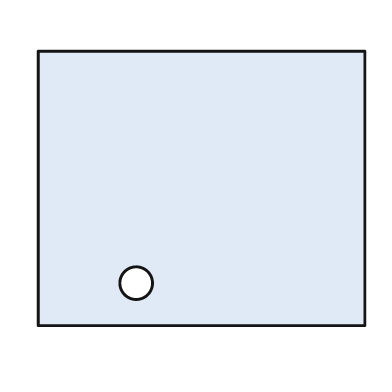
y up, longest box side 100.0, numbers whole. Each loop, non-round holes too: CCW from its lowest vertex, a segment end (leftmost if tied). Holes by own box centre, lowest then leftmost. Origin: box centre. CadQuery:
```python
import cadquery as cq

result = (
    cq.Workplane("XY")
    .moveTo(-50.0, -42.0)
    .lineTo(50.0, -42.0)
    .lineTo(50.0, 42.0)
    .lineTo(-50.0, 42.0)
    .close()
    .moveTo(-20.0, -29.0)
    .circle(5.0)
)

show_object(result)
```